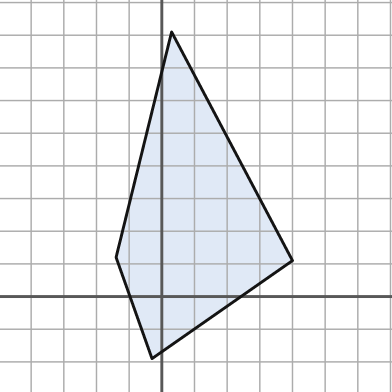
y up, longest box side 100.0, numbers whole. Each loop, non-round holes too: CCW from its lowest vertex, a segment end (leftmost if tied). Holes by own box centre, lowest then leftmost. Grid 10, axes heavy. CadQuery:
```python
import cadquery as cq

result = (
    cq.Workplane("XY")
    .moveTo(-3.0, -19.0)
    .lineTo(40.0, 11.0)
    .lineTo(3.0, 81.0)
    .lineTo(-14.0, 12.0)
    .close()
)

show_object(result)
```